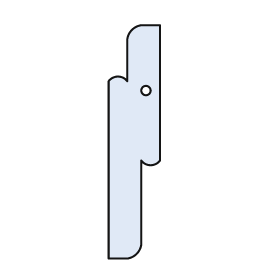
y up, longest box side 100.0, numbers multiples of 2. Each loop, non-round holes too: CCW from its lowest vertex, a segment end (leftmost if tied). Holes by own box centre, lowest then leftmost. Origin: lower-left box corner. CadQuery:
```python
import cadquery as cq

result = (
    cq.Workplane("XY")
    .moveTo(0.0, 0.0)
    .lineTo(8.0, 0.0)
    .threePointArc((12.0, 2.0), (14.0, 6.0))
    .lineTo(14.0, 42.0)
    .threePointArc((18.0, 40.0), (22.0, 42.0))
    .lineTo(22.0, 100.0)
    .lineTo(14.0, 100.0)
    .threePointArc((10.0, 98.0), (8.0, 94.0))
    .lineTo(8.0, 76.0)
    .threePointArc((4.0, 78.0), (0.0, 76.0))
    .close()
    .moveTo(16.0, 72.0)
    .circle(2.0)
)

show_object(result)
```